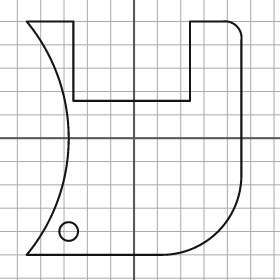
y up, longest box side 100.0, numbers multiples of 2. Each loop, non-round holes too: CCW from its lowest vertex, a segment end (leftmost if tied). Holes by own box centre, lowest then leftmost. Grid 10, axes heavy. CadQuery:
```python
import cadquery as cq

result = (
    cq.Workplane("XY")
    .moveTo(-46.0, -50.0)
    .lineTo(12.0, -50.0)
    .threePointArc((36.0, -40.0), (46.0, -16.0))
    .lineTo(46.0, 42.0)
    .threePointArc((44.0, 48.0), (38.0, 50.0))
    .lineTo(24.0, 50.0)
    .lineTo(24.0, 16.0)
    .lineTo(-26.0, 16.0)
    .lineTo(-26.0, 50.0)
    .lineTo(-46.0, 50.0)
    .threePointArc((-28.0, 0.0), (-46.0, -50.0))
    .close()
    .moveTo(-28.0, -40.0)
    .circle(4.0)
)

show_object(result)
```